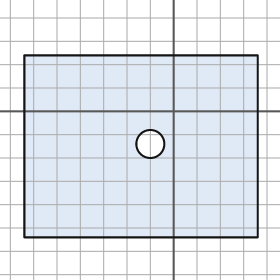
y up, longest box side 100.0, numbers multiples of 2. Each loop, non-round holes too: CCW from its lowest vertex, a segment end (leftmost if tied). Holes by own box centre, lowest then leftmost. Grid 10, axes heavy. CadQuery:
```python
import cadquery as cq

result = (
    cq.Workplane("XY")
    .moveTo(-64.0, -54.0)
    .lineTo(36.0, -54.0)
    .lineTo(36.0, 24.0)
    .lineTo(-64.0, 24.0)
    .close()
    .moveTo(-10.0, -14.0)
    .circle(6.0)
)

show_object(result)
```